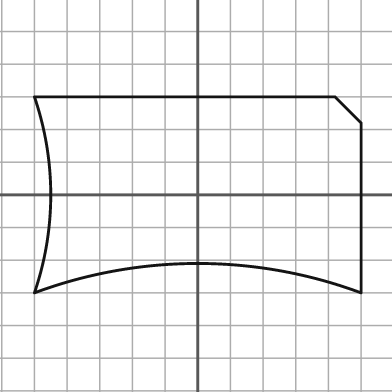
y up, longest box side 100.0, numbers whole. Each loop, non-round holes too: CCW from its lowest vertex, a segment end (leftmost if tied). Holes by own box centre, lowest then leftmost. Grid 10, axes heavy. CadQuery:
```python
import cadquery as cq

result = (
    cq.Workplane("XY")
    .moveTo(-50.0, -30.0)
    .threePointArc((0.0, -21.0), (50.0, -30.0))
    .lineTo(50.0, 22.0)
    .lineTo(42.0, 30.0)
    .lineTo(-50.0, 30.0)
    .threePointArc((-45.0, 0.0), (-50.0, -30.0))
    .close()
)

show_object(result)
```